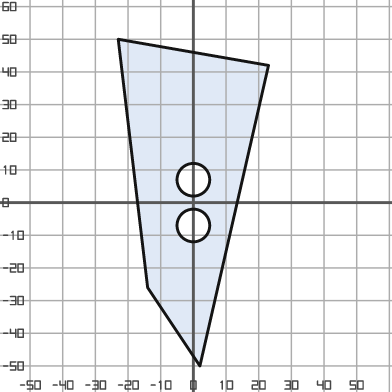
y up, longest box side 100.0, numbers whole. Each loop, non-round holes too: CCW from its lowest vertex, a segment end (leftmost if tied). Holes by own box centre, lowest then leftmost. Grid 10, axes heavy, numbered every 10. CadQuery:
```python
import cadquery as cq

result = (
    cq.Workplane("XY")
    .moveTo(2.0, -50.0)
    .lineTo(23.0, 42.0)
    .lineTo(-23.0, 50.0)
    .lineTo(-14.0, -26.0)
    .close()
    .moveTo(0.0, -7.0)
    .circle(5.0)
    .moveTo(0.0, 7.0)
    .circle(5.0)
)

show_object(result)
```